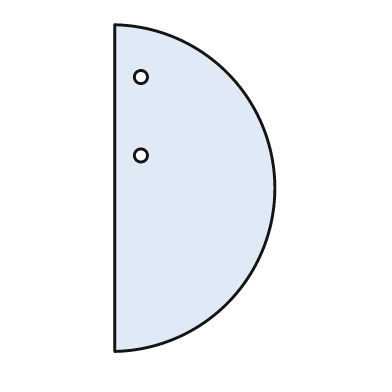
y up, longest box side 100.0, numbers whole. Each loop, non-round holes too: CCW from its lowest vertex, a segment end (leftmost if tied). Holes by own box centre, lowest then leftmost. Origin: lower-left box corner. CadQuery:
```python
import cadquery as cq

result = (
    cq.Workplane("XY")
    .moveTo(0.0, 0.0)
    .threePointArc((49.0, 50.0), (0.0, 100.0))
    .close()
    .moveTo(8.0, 60.0)
    .circle(2.0)
    .moveTo(8.0, 84.0)
    .circle(2.0)
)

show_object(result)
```